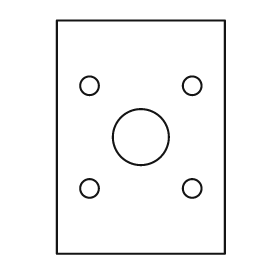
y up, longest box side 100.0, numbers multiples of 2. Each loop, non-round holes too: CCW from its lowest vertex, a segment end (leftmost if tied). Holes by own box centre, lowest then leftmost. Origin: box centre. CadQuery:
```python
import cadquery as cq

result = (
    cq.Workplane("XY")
    .moveTo(-36.0, -50.0)
    .lineTo(36.0, -50.0)
    .lineTo(36.0, 50.0)
    .lineTo(-36.0, 50.0)
    .close()
    .moveTo(-22.0, -22.0)
    .circle(4.0)
    .moveTo(22.0, -22.0)
    .circle(4.0)
    .moveTo(0.0, 0.0)
    .circle(12.0)
    .moveTo(-22.0, 22.0)
    .circle(4.0)
    .moveTo(22.0, 22.0)
    .circle(4.0)
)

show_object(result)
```